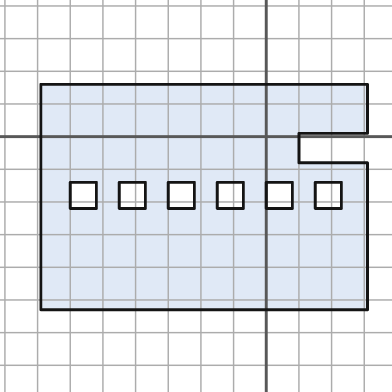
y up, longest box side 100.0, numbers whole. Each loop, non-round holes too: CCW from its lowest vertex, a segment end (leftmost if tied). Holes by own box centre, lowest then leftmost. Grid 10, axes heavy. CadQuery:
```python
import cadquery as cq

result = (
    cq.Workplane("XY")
    .moveTo(-69.0, -53.0)
    .lineTo(31.0, -53.0)
    .lineTo(31.0, -8.0)
    .lineTo(10.0, -8.0)
    .lineTo(10.0, 1.0)
    .lineTo(31.0, 1.0)
    .lineTo(31.0, 16.0)
    .lineTo(-69.0, 16.0)
    .close()
    .moveTo(-60.0, -22.0)
    .lineTo(-52.0, -22.0)
    .lineTo(-52.0, -14.0)
    .lineTo(-60.0, -14.0)
    .close()
    .moveTo(-45.0, -22.0)
    .lineTo(-37.0, -22.0)
    .lineTo(-37.0, -14.0)
    .lineTo(-45.0, -14.0)
    .close()
    .moveTo(-30.0, -22.0)
    .lineTo(-22.0, -22.0)
    .lineTo(-22.0, -14.0)
    .lineTo(-30.0, -14.0)
    .close()
    .moveTo(-15.0, -22.0)
    .lineTo(-7.0, -22.0)
    .lineTo(-7.0, -14.0)
    .lineTo(-15.0, -14.0)
    .close()
    .moveTo(0.0, -22.0)
    .lineTo(8.0, -22.0)
    .lineTo(8.0, -14.0)
    .lineTo(0.0, -14.0)
    .close()
    .moveTo(15.0, -22.0)
    .lineTo(23.0, -22.0)
    .lineTo(23.0, -14.0)
    .lineTo(15.0, -14.0)
    .close()
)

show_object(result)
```